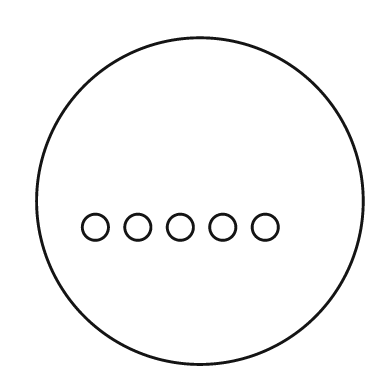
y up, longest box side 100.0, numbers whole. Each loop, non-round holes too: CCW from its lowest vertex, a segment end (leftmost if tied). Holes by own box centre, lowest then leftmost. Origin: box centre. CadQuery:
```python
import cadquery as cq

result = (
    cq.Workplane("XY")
    .moveTo(0.0, 0.0)
    .circle(50.0)
    .moveTo(-32.0, -8.0)
    .circle(4.0)
    .moveTo(-19.0, -8.0)
    .circle(4.0)
    .moveTo(-6.0, -8.0)
    .circle(4.0)
    .moveTo(7.0, -8.0)
    .circle(4.0)
    .moveTo(20.0, -8.0)
    .circle(4.0)
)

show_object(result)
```